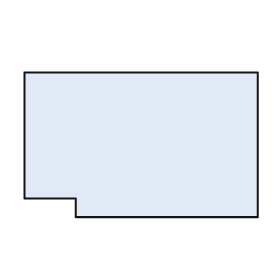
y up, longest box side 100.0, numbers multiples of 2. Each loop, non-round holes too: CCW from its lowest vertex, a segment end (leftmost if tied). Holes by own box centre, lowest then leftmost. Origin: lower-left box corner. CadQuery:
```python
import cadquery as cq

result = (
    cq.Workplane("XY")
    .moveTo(22.0, 0.0)
    .lineTo(100.0, 0.0)
    .lineTo(100.0, 62.0)
    .lineTo(0.0, 62.0)
    .lineTo(0.0, 8.0)
    .lineTo(22.0, 8.0)
    .close()
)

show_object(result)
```